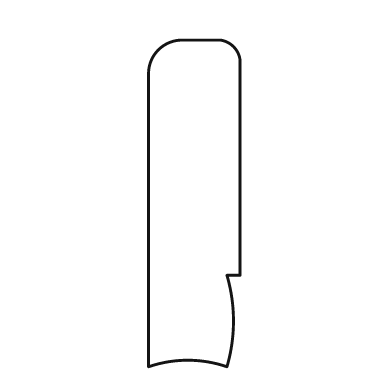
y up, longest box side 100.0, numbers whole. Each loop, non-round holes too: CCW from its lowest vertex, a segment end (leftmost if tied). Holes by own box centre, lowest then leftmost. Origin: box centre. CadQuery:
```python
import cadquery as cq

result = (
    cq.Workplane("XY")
    .moveTo(-14.0, -50.0)
    .threePointArc((-2.0, -48.0), (10.0, -50.0))
    .threePointArc((12.0, -36.0), (10.0, -22.0))
    .lineTo(14.0, -22.0)
    .lineTo(14.0, 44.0)
    .threePointArc((12.0, 48.0), (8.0, 50.0))
    .lineTo(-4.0, 50.0)
    .threePointArc((-11.0, 47.0), (-14.0, 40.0))
    .close()
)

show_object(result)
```